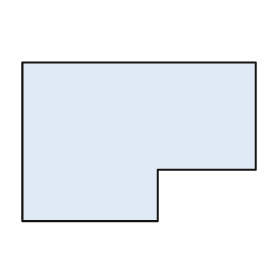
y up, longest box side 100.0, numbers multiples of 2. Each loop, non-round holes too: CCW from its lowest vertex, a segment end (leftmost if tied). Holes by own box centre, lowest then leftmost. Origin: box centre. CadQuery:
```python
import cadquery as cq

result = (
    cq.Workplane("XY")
    .moveTo(-50.0, -34.0)
    .lineTo(8.0, -34.0)
    .lineTo(8.0, -12.0)
    .lineTo(50.0, -12.0)
    .lineTo(50.0, 34.0)
    .lineTo(-50.0, 34.0)
    .close()
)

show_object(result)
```